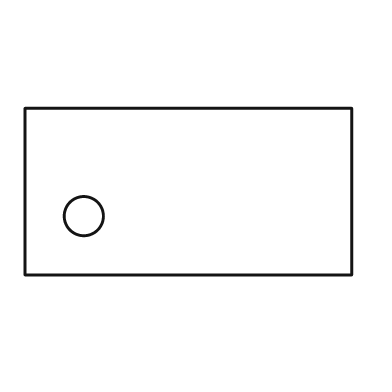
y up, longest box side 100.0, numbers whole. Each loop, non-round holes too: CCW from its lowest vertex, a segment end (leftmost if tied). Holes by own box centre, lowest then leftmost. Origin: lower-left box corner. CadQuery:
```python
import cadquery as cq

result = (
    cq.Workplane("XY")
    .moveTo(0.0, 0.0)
    .lineTo(100.0, 0.0)
    .lineTo(100.0, 51.0)
    .lineTo(0.0, 51.0)
    .close()
    .moveTo(18.0, 18.0)
    .circle(6.0)
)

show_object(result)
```